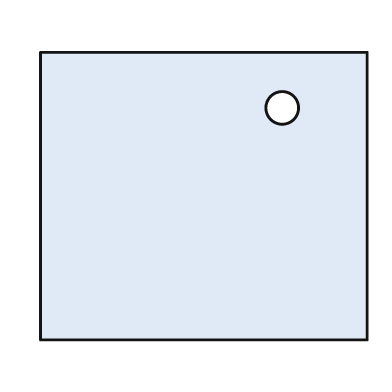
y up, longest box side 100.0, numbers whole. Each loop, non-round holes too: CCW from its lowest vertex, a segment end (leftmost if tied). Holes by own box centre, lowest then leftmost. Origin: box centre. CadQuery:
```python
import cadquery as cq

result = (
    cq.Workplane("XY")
    .moveTo(-50.0, -44.0)
    .lineTo(50.0, -44.0)
    .lineTo(50.0, 44.0)
    .lineTo(-50.0, 44.0)
    .close()
    .moveTo(24.0, 27.0)
    .circle(5.0)
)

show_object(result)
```